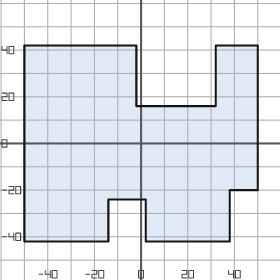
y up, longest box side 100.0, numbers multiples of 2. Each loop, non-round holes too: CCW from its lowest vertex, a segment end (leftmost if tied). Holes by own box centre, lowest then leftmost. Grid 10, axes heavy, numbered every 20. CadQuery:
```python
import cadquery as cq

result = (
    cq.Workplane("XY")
    .moveTo(-50.0, -42.0)
    .lineTo(-14.0, -42.0)
    .lineTo(-14.0, -24.0)
    .lineTo(2.0, -24.0)
    .lineTo(2.0, -42.0)
    .lineTo(38.0, -42.0)
    .lineTo(38.0, -20.0)
    .lineTo(50.0, -20.0)
    .lineTo(50.0, 42.0)
    .lineTo(32.0, 42.0)
    .lineTo(32.0, 16.0)
    .lineTo(-2.0, 16.0)
    .lineTo(-2.0, 42.0)
    .lineTo(-50.0, 42.0)
    .close()
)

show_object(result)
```